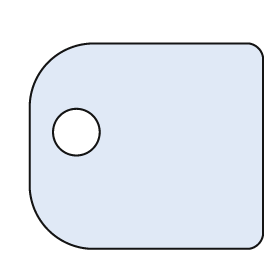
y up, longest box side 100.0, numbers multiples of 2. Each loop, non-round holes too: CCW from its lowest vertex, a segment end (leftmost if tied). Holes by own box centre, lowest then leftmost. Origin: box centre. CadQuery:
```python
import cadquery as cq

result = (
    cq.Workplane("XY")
    .moveTo(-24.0, -44.0)
    .lineTo(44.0, -44.0)
    .threePointArc((48.0, -42.0), (50.0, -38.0))
    .lineTo(50.0, 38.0)
    .threePointArc((48.0, 42.0), (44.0, 44.0))
    .lineTo(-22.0, 44.0)
    .threePointArc((-42.0, 36.0), (-50.0, 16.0))
    .lineTo(-50.0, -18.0)
    .threePointArc((-42.0, -36.0), (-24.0, -44.0))
    .close()
    .moveTo(-30.0, 6.0)
    .circle(10.0)
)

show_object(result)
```